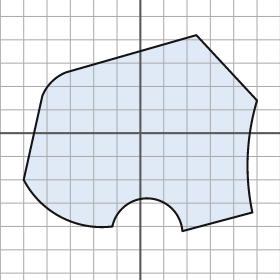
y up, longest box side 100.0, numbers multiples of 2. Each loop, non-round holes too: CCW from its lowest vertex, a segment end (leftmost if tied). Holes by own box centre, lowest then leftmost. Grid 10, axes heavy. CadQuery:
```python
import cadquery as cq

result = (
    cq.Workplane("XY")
    .moveTo(18.0, -42.0)
    .lineTo(48.0, -34.0)
    .threePointArc((46.0, -10.0), (50.0, 14.0))
    .lineTo(24.0, 42.0)
    .lineTo(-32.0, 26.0)
    .threePointArc((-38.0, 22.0), (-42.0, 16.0))
    .lineTo(-50.0, -20.0)
    .threePointArc((-34.0, -36.0), (-12.0, -40.0))
    .threePointArc((4.0, -28.0), (18.0, -42.0))
    .close()
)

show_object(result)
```